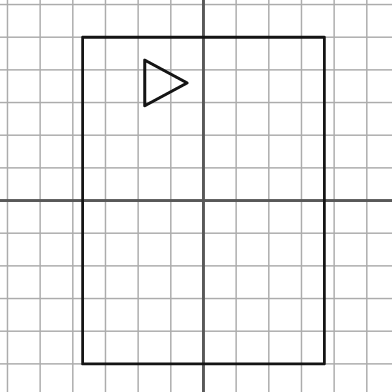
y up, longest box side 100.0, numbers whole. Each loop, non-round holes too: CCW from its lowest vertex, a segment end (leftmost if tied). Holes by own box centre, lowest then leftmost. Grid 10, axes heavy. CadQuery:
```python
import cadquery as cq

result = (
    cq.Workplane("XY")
    .moveTo(-37.0, -50.0)
    .lineTo(37.0, -50.0)
    .lineTo(37.0, 50.0)
    .lineTo(-37.0, 50.0)
    .close()
    .moveTo(-18.0, 29.0)
    .lineTo(-5.0, 36.0)
    .lineTo(-18.0, 43.0)
    .close()
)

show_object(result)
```